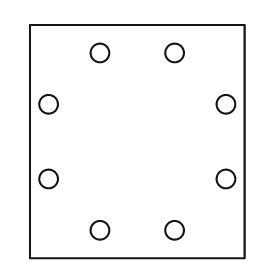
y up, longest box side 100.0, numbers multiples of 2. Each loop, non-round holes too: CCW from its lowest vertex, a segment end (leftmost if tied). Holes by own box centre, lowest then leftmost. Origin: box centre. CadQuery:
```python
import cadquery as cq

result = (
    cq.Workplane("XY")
    .moveTo(-46.0, -50.0)
    .lineTo(46.0, -50.0)
    .lineTo(46.0, 50.0)
    .lineTo(-46.0, 50.0)
    .close()
    .moveTo(-16.0, -38.0)
    .circle(4.0)
    .moveTo(16.0, -38.0)
    .circle(4.0)
    .moveTo(-38.0, -16.0)
    .circle(4.0)
    .moveTo(38.0, -16.0)
    .circle(4.0)
    .moveTo(-38.0, 16.0)
    .circle(4.0)
    .moveTo(38.0, 16.0)
    .circle(4.0)
    .moveTo(-16.0, 38.0)
    .circle(4.0)
    .moveTo(16.0, 38.0)
    .circle(4.0)
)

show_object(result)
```